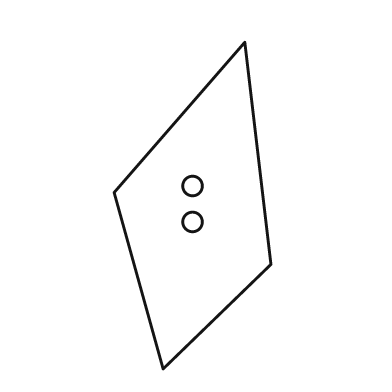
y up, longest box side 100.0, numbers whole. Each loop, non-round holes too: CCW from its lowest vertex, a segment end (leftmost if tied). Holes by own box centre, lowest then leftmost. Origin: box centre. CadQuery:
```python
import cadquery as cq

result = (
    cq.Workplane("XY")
    .moveTo(-9.0, -50.0)
    .lineTo(24.0, -18.0)
    .lineTo(16.0, 50.0)
    .lineTo(-24.0, 4.0)
    .close()
    .moveTo(0.0, -5.0)
    .circle(3.0)
    .moveTo(0.0, 6.0)
    .circle(3.0)
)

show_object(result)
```